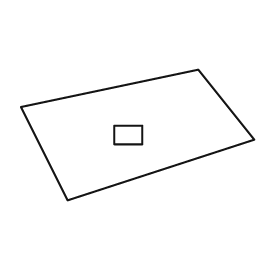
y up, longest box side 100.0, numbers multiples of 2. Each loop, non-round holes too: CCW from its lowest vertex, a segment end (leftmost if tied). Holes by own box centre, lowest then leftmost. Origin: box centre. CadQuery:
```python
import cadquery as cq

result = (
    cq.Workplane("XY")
    .moveTo(-30.0, -28.0)
    .lineTo(50.0, -2.0)
    .lineTo(26.0, 28.0)
    .lineTo(-50.0, 12.0)
    .close()
    .moveTo(-10.0, -4.0)
    .lineTo(2.0, -4.0)
    .lineTo(2.0, 4.0)
    .lineTo(-10.0, 4.0)
    .close()
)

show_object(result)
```